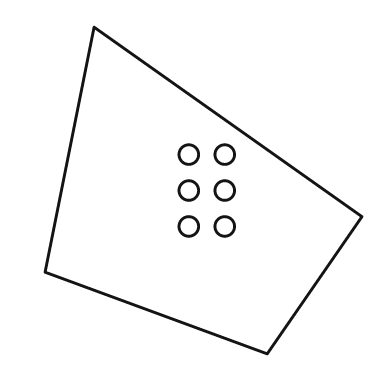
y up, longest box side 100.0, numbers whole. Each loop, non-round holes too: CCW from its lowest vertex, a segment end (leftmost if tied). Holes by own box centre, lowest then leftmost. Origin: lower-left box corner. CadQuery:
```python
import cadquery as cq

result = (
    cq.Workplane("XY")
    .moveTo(68.0, 0.0)
    .lineTo(97.0, 42.0)
    .lineTo(15.0, 100.0)
    .lineTo(0.0, 25.0)
    .close()
    .moveTo(44.0, 39.0)
    .circle(3.0)
    .moveTo(55.0, 39.0)
    .circle(3.0)
    .moveTo(44.0, 50.0)
    .circle(3.0)
    .moveTo(55.0, 50.0)
    .circle(3.0)
    .moveTo(44.0, 61.0)
    .circle(3.0)
    .moveTo(55.0, 61.0)
    .circle(3.0)
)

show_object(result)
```